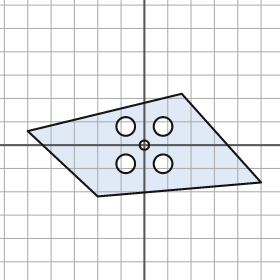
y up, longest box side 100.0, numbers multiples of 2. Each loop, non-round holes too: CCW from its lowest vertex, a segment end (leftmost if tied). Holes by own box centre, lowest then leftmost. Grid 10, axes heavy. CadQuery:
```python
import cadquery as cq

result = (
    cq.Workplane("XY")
    .moveTo(-20.0, -22.0)
    .lineTo(50.0, -16.0)
    .lineTo(16.0, 22.0)
    .lineTo(-50.0, 6.0)
    .close()
    .moveTo(-8.0, -8.0)
    .circle(4.0)
    .moveTo(8.0, -8.0)
    .circle(4.0)
    .moveTo(0.0, 0.0)
    .circle(2.0)
    .moveTo(-8.0, 8.0)
    .circle(4.0)
    .moveTo(8.0, 8.0)
    .circle(4.0)
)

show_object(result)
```